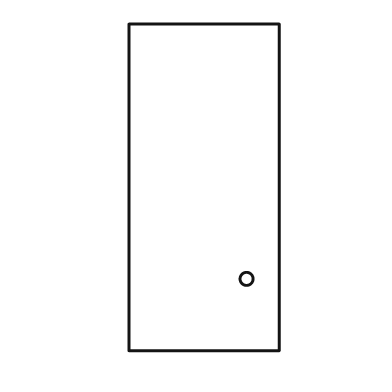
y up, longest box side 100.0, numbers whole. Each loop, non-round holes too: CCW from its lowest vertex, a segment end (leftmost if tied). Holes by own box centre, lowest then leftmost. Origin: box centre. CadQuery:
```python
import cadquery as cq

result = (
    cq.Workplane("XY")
    .moveTo(-23.0, -50.0)
    .lineTo(23.0, -50.0)
    .lineTo(23.0, 50.0)
    .lineTo(-23.0, 50.0)
    .close()
    .moveTo(13.0, -28.0)
    .circle(2.0)
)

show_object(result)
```